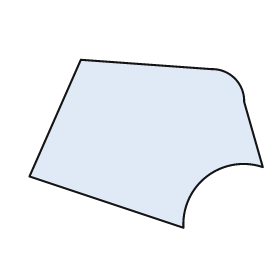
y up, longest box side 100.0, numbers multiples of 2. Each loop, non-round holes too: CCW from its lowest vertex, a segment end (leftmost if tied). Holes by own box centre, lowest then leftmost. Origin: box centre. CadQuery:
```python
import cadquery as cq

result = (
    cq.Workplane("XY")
    .moveTo(16.0, -36.0)
    .threePointArc((26.0, -14.0), (50.0, -10.0))
    .lineTo(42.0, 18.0)
    .threePointArc((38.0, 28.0), (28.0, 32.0))
    .lineTo(-28.0, 36.0)
    .lineTo(-50.0, -14.0)
    .close()
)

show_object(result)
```